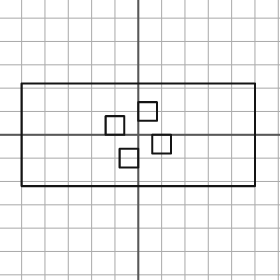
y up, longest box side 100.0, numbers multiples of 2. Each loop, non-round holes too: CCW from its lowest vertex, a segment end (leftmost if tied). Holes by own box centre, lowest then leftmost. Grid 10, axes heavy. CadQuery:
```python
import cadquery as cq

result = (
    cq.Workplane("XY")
    .moveTo(-50.0, -22.0)
    .lineTo(50.0, -22.0)
    .lineTo(50.0, 22.0)
    .lineTo(-50.0, 22.0)
    .close()
    .moveTo(-8.0, -14.0)
    .lineTo(0.0, -14.0)
    .lineTo(0.0, -6.0)
    .lineTo(-8.0, -6.0)
    .close()
    .moveTo(6.0, -8.0)
    .lineTo(14.0, -8.0)
    .lineTo(14.0, 0.0)
    .lineTo(6.0, 0.0)
    .close()
    .moveTo(-14.0, 0.0)
    .lineTo(-6.0, 0.0)
    .lineTo(-6.0, 8.0)
    .lineTo(-14.0, 8.0)
    .close()
    .moveTo(0.0, 6.0)
    .lineTo(8.0, 6.0)
    .lineTo(8.0, 14.0)
    .lineTo(0.0, 14.0)
    .close()
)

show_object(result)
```